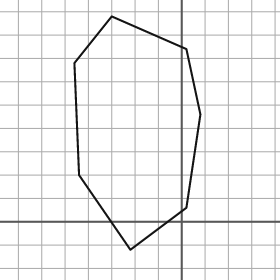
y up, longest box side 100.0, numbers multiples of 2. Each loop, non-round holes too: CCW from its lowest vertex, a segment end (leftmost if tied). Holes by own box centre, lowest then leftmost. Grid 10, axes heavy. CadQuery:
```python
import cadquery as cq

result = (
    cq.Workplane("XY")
    .moveTo(-22.0, -12.0)
    .lineTo(2.0, 6.0)
    .lineTo(8.0, 46.0)
    .lineTo(2.0, 74.0)
    .lineTo(-30.0, 88.0)
    .lineTo(-46.0, 68.0)
    .lineTo(-44.0, 20.0)
    .close()
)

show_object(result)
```